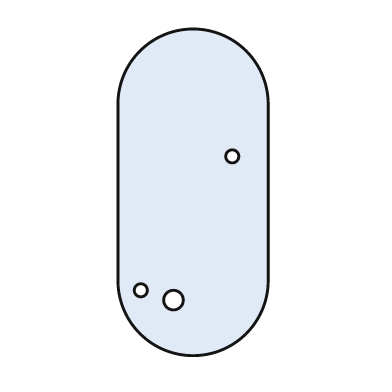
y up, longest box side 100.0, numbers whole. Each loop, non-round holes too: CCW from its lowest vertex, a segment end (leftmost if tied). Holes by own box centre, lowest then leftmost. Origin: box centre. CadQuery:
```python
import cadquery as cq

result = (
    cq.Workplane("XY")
    .moveTo(-23.0, -27.0)
    .threePointArc((0.0, -50.0), (23.0, -27.0))
    .lineTo(23.0, 27.0)
    .threePointArc((0.0, 50.0), (-23.0, 27.0))
    .close()
    .moveTo(-6.0, -33.0)
    .circle(3.0)
    .moveTo(-16.0, -30.0)
    .circle(2.0)
    .moveTo(12.0, 11.0)
    .circle(2.0)
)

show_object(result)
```